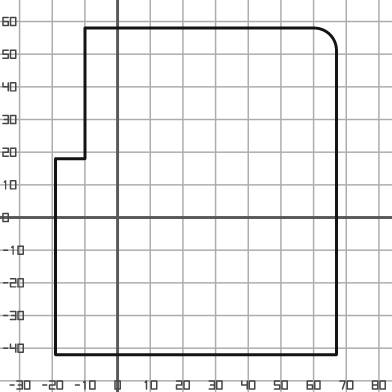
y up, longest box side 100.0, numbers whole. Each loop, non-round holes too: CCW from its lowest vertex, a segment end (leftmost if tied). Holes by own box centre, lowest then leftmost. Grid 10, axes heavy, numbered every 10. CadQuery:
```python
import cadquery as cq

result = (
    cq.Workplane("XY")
    .moveTo(-19.0, -42.0)
    .lineTo(67.0, -42.0)
    .lineTo(67.0, 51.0)
    .threePointArc((65.0, 56.0), (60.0, 58.0))
    .lineTo(-10.0, 58.0)
    .lineTo(-10.0, 18.0)
    .lineTo(-19.0, 18.0)
    .close()
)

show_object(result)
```